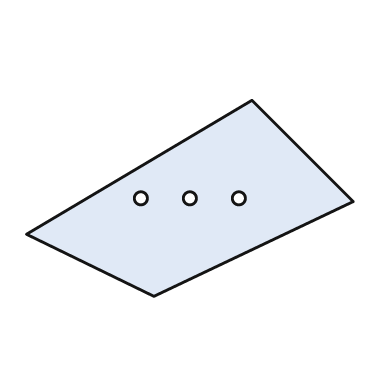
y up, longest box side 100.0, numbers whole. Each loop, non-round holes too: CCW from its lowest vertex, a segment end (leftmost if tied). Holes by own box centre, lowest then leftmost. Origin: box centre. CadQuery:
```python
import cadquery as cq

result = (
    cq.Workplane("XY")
    .moveTo(-11.0, -30.0)
    .lineTo(50.0, -1.0)
    .lineTo(19.0, 30.0)
    .lineTo(-50.0, -11.0)
    .close()
    .moveTo(-15.0, 0.0)
    .circle(2.0)
    .moveTo(0.0, 0.0)
    .circle(2.0)
    .moveTo(15.0, 0.0)
    .circle(2.0)
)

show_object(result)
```